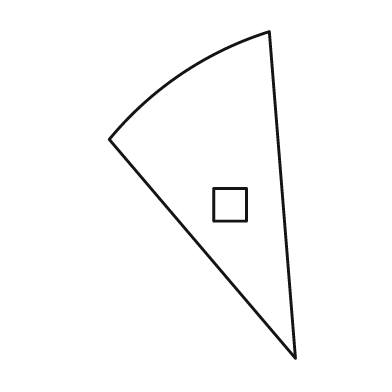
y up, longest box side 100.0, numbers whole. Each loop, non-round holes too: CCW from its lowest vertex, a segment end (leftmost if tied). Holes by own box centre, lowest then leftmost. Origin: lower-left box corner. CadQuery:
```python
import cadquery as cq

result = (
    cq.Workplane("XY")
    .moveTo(57.0, 0.0)
    .lineTo(49.0, 100.0)
    .threePointArc((22.0, 87.0), (0.0, 67.0))
    .close()
    .moveTo(32.0, 42.0)
    .lineTo(42.0, 42.0)
    .lineTo(42.0, 52.0)
    .lineTo(32.0, 52.0)
    .close()
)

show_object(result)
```